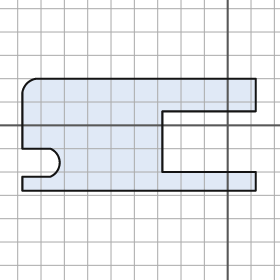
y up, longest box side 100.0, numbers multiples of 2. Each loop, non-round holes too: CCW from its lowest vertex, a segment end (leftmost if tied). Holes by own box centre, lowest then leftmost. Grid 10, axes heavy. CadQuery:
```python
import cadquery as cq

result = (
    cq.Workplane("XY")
    .moveTo(-88.0, -28.0)
    .lineTo(12.0, -28.0)
    .lineTo(12.0, -20.0)
    .lineTo(-28.0, -20.0)
    .lineTo(-28.0, 6.0)
    .lineTo(12.0, 6.0)
    .lineTo(12.0, 20.0)
    .lineTo(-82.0, 20.0)
    .threePointArc((-86.0, 18.0), (-88.0, 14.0))
    .lineTo(-88.0, -10.0)
    .lineTo(-76.0, -10.0)
    .threePointArc((-72.0, -16.0), (-76.0, -22.0))
    .lineTo(-88.0, -22.0)
    .close()
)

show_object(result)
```